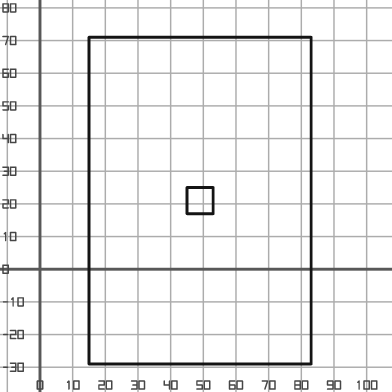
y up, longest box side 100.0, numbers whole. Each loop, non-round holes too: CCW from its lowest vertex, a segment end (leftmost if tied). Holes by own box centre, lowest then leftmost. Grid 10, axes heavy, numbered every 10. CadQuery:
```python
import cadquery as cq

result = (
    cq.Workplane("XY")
    .moveTo(15.0, -29.0)
    .lineTo(83.0, -29.0)
    .lineTo(83.0, 71.0)
    .lineTo(15.0, 71.0)
    .close()
    .moveTo(45.0, 17.0)
    .lineTo(53.0, 17.0)
    .lineTo(53.0, 25.0)
    .lineTo(45.0, 25.0)
    .close()
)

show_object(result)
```